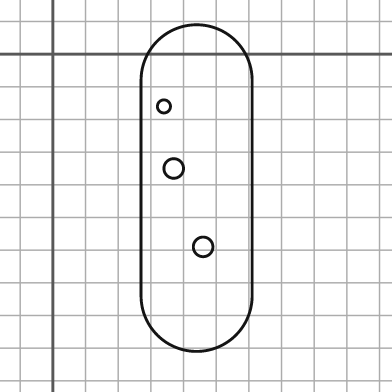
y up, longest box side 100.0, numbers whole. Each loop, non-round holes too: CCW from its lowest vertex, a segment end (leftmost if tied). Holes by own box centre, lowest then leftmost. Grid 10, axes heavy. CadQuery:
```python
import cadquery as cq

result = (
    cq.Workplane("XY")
    .moveTo(27.0, -74.0)
    .threePointArc((44.0, -91.0), (61.0, -74.0))
    .lineTo(61.0, -8.0)
    .threePointArc((44.0, 9.0), (27.0, -8.0))
    .close()
    .moveTo(46.0, -59.0)
    .circle(3.0)
    .moveTo(37.0, -35.0)
    .circle(3.0)
    .moveTo(34.0, -16.0)
    .circle(2.0)
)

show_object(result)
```